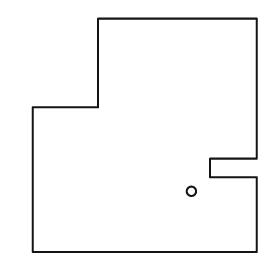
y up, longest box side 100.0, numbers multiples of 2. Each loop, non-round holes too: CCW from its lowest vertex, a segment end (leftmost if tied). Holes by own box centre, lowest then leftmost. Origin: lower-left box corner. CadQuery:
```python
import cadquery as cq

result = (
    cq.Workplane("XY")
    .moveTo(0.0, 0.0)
    .lineTo(96.0, 0.0)
    .lineTo(96.0, 32.0)
    .lineTo(76.0, 32.0)
    .lineTo(76.0, 40.0)
    .lineTo(96.0, 40.0)
    .lineTo(96.0, 100.0)
    .lineTo(28.0, 100.0)
    .lineTo(28.0, 62.0)
    .lineTo(0.0, 62.0)
    .close()
    .moveTo(68.0, 26.0)
    .circle(2.0)
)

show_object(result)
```